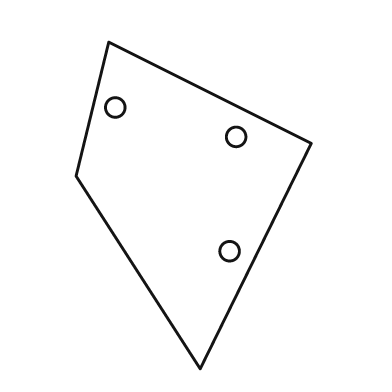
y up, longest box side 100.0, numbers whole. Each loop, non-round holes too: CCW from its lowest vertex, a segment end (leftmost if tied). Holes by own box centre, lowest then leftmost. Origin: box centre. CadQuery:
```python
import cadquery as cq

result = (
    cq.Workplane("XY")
    .moveTo(2.0, -50.0)
    .lineTo(36.0, 19.0)
    .lineTo(-26.0, 50.0)
    .lineTo(-36.0, 9.0)
    .close()
    .moveTo(11.0, -14.0)
    .circle(3.0)
    .moveTo(13.0, 21.0)
    .circle(3.0)
    .moveTo(-24.0, 30.0)
    .circle(3.0)
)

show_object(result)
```